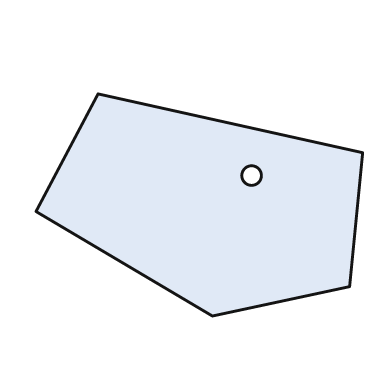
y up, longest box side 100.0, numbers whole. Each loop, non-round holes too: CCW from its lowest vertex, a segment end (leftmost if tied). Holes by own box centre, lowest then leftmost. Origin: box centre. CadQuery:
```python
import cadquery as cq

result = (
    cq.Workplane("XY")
    .moveTo(4.0, -34.0)
    .lineTo(46.0, -25.0)
    .lineTo(50.0, 16.0)
    .lineTo(-31.0, 34.0)
    .lineTo(-50.0, -2.0)
    .close()
    .moveTo(16.0, 9.0)
    .circle(3.0)
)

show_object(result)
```